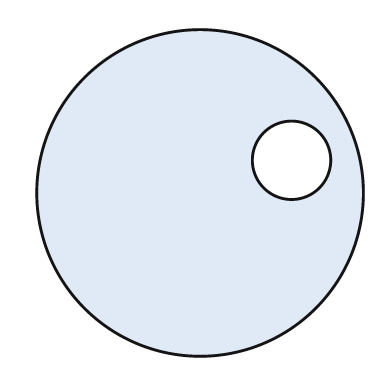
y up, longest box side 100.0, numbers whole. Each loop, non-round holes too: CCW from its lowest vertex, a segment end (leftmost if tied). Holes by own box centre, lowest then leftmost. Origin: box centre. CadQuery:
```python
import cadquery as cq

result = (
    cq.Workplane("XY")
    .moveTo(0.0, 0.0)
    .circle(50.0)
    .moveTo(28.0, 10.0)
    .circle(12.0)
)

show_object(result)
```